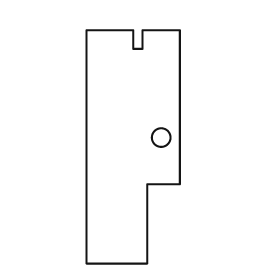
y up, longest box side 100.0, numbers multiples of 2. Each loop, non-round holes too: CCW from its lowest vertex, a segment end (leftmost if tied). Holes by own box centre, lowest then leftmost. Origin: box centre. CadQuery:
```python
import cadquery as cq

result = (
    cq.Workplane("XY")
    .moveTo(-20.0, -50.0)
    .lineTo(6.0, -50.0)
    .lineTo(6.0, -16.0)
    .lineTo(20.0, -16.0)
    .lineTo(20.0, 50.0)
    .lineTo(4.0, 50.0)
    .lineTo(4.0, 42.0)
    .lineTo(0.0, 42.0)
    .lineTo(0.0, 50.0)
    .lineTo(-20.0, 50.0)
    .close()
    .moveTo(12.0, 4.0)
    .circle(4.0)
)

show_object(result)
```